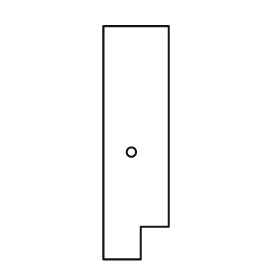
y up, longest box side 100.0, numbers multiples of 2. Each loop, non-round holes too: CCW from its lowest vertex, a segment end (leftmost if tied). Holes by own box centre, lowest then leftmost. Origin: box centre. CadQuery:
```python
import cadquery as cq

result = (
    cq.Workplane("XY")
    .moveTo(-14.0, -50.0)
    .lineTo(2.0, -50.0)
    .lineTo(2.0, -36.0)
    .lineTo(14.0, -36.0)
    .lineTo(14.0, 50.0)
    .lineTo(-14.0, 50.0)
    .close()
    .moveTo(-2.0, -4.0)
    .circle(2.0)
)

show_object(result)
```